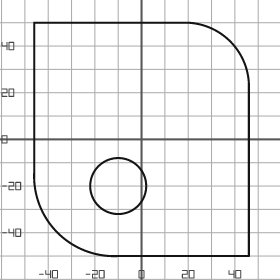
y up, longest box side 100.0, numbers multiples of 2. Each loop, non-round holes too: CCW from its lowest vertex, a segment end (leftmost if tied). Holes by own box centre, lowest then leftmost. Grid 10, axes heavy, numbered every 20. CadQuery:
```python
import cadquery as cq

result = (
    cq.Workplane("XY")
    .moveTo(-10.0, -50.0)
    .lineTo(46.0, -50.0)
    .lineTo(46.0, 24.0)
    .threePointArc((38.0, 42.0), (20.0, 50.0))
    .lineTo(-46.0, 50.0)
    .lineTo(-46.0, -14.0)
    .threePointArc((-36.0, -40.0), (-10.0, -50.0))
    .close()
    .moveTo(-10.0, -20.0)
    .circle(12.0)
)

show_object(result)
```